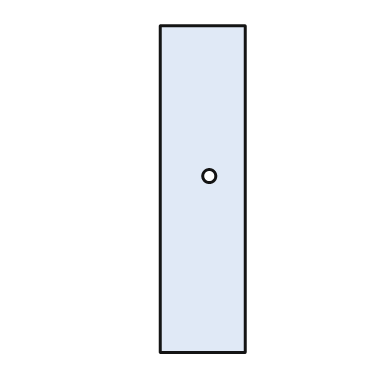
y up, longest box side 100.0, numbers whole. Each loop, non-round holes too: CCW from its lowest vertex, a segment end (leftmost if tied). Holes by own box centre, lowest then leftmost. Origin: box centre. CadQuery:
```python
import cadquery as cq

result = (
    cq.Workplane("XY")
    .moveTo(-13.0, -50.0)
    .lineTo(13.0, -50.0)
    .lineTo(13.0, 50.0)
    .lineTo(-13.0, 50.0)
    .close()
    .moveTo(2.0, 4.0)
    .circle(2.0)
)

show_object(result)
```